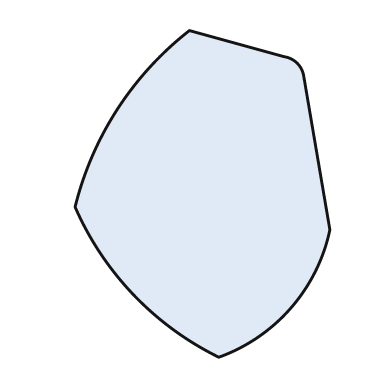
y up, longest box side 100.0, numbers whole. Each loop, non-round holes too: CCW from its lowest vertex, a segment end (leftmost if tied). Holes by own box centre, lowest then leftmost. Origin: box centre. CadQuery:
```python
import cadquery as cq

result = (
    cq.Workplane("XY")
    .moveTo(5.0, -50.0)
    .threePointArc((27.0, -35.0), (39.0, -11.0))
    .lineTo(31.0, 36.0)
    .threePointArc((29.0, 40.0), (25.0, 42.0))
    .lineTo(-4.0, 50.0)
    .threePointArc((-26.0, 26.0), (-39.0, -4.0))
    .threePointArc((-21.0, -31.0), (5.0, -50.0))
    .close()
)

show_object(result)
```